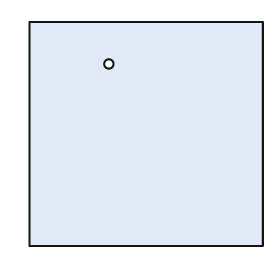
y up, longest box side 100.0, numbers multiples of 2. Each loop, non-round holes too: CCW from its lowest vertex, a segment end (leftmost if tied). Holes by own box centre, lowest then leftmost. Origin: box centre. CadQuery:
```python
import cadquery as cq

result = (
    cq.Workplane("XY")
    .moveTo(-50.0, -48.0)
    .lineTo(50.0, -48.0)
    .lineTo(50.0, 48.0)
    .lineTo(-50.0, 48.0)
    .close()
    .moveTo(-16.0, 30.0)
    .circle(2.0)
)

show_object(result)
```